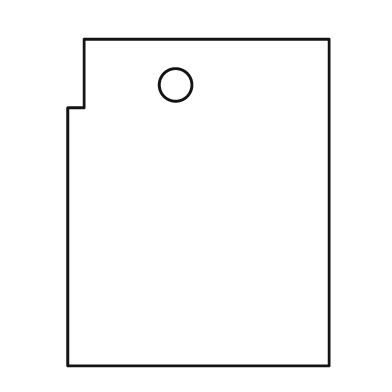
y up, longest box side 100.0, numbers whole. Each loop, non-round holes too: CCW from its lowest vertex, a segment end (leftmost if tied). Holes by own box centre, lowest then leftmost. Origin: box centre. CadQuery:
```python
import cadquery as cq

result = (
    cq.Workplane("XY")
    .moveTo(-40.0, -50.0)
    .lineTo(40.0, -50.0)
    .lineTo(40.0, 50.0)
    .lineTo(-35.0, 50.0)
    .lineTo(-35.0, 29.0)
    .lineTo(-40.0, 29.0)
    .close()
    .moveTo(-7.0, 36.0)
    .circle(5.0)
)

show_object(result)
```